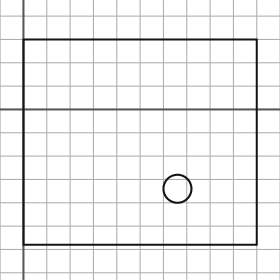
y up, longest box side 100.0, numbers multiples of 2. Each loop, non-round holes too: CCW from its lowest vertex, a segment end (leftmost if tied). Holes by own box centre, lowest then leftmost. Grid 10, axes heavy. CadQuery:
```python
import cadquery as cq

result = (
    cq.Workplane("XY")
    .moveTo(0.0, -58.0)
    .lineTo(100.0, -58.0)
    .lineTo(100.0, 30.0)
    .lineTo(0.0, 30.0)
    .close()
    .moveTo(66.0, -34.0)
    .circle(6.0)
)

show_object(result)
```